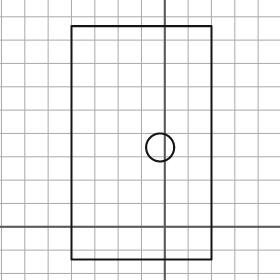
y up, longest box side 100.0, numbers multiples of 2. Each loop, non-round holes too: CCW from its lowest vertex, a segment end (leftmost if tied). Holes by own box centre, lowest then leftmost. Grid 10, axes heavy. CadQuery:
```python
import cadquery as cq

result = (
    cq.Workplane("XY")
    .moveTo(-40.0, -14.0)
    .lineTo(20.0, -14.0)
    .lineTo(20.0, 86.0)
    .lineTo(-40.0, 86.0)
    .close()
    .moveTo(-2.0, 34.0)
    .circle(6.0)
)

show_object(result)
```